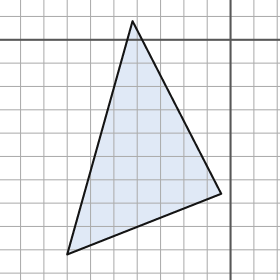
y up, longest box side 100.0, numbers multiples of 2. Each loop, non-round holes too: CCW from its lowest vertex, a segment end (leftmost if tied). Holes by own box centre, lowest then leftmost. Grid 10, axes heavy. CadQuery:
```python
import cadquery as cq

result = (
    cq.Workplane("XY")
    .moveTo(-70.0, -92.0)
    .lineTo(-4.0, -66.0)
    .lineTo(-42.0, 8.0)
    .close()
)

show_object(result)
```